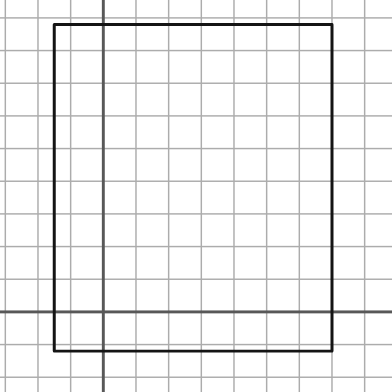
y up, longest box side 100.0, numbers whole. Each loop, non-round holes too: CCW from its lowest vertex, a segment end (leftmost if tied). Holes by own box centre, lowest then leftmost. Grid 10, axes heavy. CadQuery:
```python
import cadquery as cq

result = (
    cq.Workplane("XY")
    .moveTo(-15.0, -12.0)
    .lineTo(70.0, -12.0)
    .lineTo(70.0, 88.0)
    .lineTo(-15.0, 88.0)
    .close()
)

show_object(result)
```